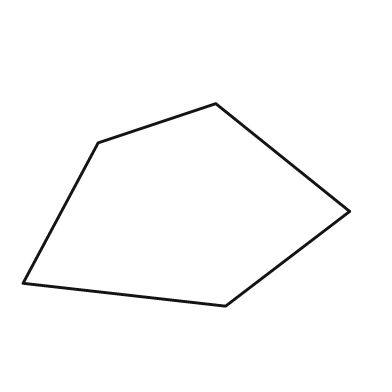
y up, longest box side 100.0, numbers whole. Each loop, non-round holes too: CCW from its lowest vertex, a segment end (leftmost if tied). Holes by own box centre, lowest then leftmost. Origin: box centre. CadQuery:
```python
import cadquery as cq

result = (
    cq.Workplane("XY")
    .moveTo(12.0, -31.0)
    .lineTo(50.0, -2.0)
    .lineTo(9.0, 31.0)
    .lineTo(-27.0, 19.0)
    .lineTo(-50.0, -24.0)
    .close()
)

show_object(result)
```